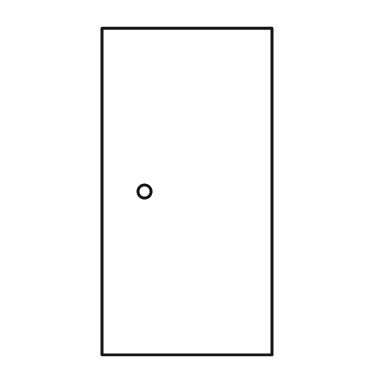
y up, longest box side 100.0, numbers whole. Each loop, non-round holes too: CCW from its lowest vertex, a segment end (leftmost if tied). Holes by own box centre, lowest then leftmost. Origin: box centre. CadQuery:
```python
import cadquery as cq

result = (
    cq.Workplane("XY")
    .moveTo(-26.0, -50.0)
    .lineTo(26.0, -50.0)
    .lineTo(26.0, 50.0)
    .lineTo(-26.0, 50.0)
    .close()
    .moveTo(-13.0, 0.0)
    .circle(2.0)
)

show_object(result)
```